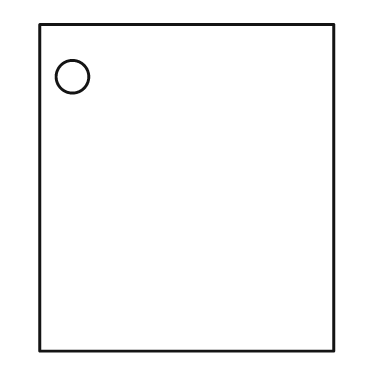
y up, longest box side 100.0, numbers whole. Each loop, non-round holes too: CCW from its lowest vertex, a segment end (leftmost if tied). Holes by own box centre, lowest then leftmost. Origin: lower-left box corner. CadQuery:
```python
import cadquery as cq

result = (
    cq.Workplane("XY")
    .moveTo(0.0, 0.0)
    .lineTo(90.0, 0.0)
    .lineTo(90.0, 100.0)
    .lineTo(0.0, 100.0)
    .close()
    .moveTo(10.0, 84.0)
    .circle(5.0)
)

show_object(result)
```